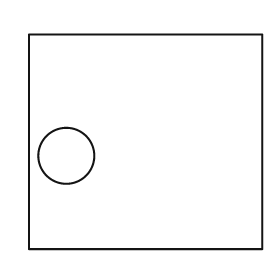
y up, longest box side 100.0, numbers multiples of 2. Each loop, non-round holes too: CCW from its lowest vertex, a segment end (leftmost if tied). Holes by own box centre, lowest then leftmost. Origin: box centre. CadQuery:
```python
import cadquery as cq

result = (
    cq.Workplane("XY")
    .moveTo(-50.0, -46.0)
    .lineTo(50.0, -46.0)
    .lineTo(50.0, 46.0)
    .lineTo(-50.0, 46.0)
    .close()
    .moveTo(-34.0, -6.0)
    .circle(12.0)
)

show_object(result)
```